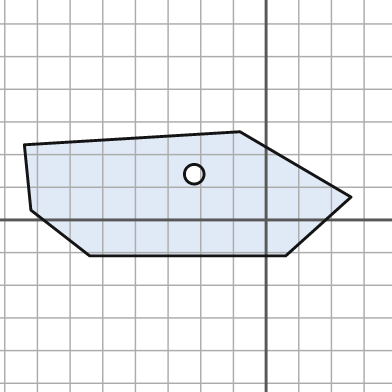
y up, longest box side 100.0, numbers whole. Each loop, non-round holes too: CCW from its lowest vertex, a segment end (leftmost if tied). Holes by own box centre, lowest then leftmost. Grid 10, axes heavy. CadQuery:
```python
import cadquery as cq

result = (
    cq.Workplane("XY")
    .moveTo(-54.0, -11.0)
    .lineTo(6.0, -11.0)
    .lineTo(26.0, 7.0)
    .lineTo(-8.0, 27.0)
    .lineTo(-74.0, 23.0)
    .lineTo(-72.0, 3.0)
    .close()
    .moveTo(-22.0, 14.0)
    .circle(3.0)
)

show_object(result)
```